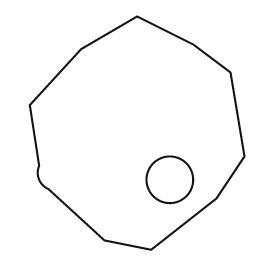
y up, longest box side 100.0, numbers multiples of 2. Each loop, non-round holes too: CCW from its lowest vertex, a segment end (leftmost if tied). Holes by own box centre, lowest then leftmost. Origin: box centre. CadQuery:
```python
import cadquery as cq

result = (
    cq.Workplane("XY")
    .moveTo(6.0, -50.0)
    .lineTo(34.0, -28.0)
    .lineTo(46.0, -10.0)
    .lineTo(40.0, 26.0)
    .lineTo(24.0, 38.0)
    .lineTo(0.0, 50.0)
    .lineTo(-24.0, 36.0)
    .lineTo(-46.0, 12.0)
    .lineTo(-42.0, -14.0)
    .threePointArc((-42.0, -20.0), (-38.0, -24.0))
    .lineTo(-14.0, -46.0)
    .close()
    .moveTo(14.0, -20.0)
    .circle(10.0)
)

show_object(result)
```